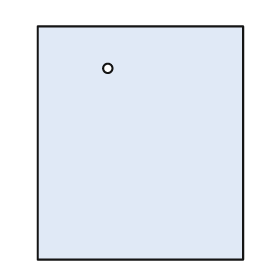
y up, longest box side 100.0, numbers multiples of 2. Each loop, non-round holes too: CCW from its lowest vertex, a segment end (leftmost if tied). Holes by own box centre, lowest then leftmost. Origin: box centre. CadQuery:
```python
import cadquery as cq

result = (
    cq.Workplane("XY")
    .moveTo(-44.0, -50.0)
    .lineTo(44.0, -50.0)
    .lineTo(44.0, 50.0)
    .lineTo(-44.0, 50.0)
    .close()
    .moveTo(-14.0, 32.0)
    .circle(2.0)
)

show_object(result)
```